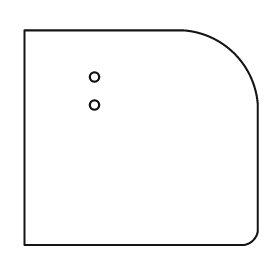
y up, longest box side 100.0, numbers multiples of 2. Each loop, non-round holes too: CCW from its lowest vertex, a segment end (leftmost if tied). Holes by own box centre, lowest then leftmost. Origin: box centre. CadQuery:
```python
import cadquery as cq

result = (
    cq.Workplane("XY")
    .moveTo(-50.0, -46.0)
    .lineTo(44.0, -46.0)
    .threePointArc((48.0, -44.0), (50.0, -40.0))
    .lineTo(50.0, 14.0)
    .threePointArc((40.0, 36.0), (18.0, 46.0))
    .lineTo(-50.0, 46.0)
    .close()
    .moveTo(-20.0, 14.0)
    .circle(2.0)
    .moveTo(-20.0, 26.0)
    .circle(2.0)
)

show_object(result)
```